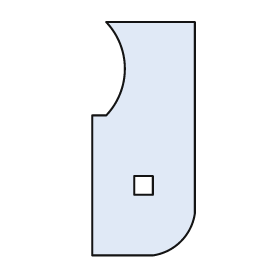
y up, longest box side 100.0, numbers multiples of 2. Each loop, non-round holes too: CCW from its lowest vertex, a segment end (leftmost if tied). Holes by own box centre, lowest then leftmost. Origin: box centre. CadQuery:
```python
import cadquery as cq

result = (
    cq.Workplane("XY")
    .moveTo(-22.0, -50.0)
    .lineTo(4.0, -50.0)
    .threePointArc((16.0, -44.0), (22.0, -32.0))
    .lineTo(22.0, 50.0)
    .lineTo(-16.0, 50.0)
    .threePointArc((-8.0, 30.0), (-16.0, 10.0))
    .lineTo(-22.0, 10.0)
    .close()
    .moveTo(-4.0, -24.0)
    .lineTo(4.0, -24.0)
    .lineTo(4.0, -16.0)
    .lineTo(-4.0, -16.0)
    .close()
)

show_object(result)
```